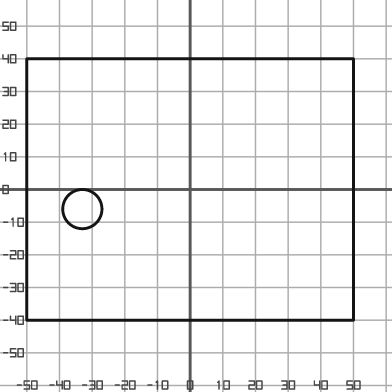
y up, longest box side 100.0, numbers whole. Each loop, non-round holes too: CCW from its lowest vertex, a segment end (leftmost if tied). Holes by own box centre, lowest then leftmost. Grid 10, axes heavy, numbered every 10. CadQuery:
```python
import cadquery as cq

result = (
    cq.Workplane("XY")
    .moveTo(-50.0, -40.0)
    .lineTo(50.0, -40.0)
    .lineTo(50.0, 40.0)
    .lineTo(-50.0, 40.0)
    .close()
    .moveTo(-33.0, -6.0)
    .circle(6.0)
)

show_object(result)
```